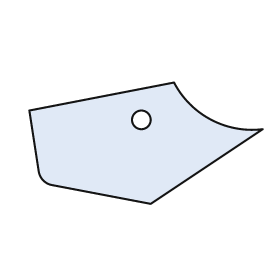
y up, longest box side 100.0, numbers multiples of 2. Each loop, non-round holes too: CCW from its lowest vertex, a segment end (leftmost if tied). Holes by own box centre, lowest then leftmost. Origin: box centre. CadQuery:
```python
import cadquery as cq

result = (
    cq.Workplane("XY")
    .moveTo(2.0, -26.0)
    .lineTo(50.0, 6.0)
    .threePointArc((28.0, 10.0), (12.0, 26.0))
    .lineTo(-50.0, 14.0)
    .lineTo(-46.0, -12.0)
    .threePointArc((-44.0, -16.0), (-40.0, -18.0))
    .close()
    .moveTo(-2.0, 10.0)
    .circle(4.0)
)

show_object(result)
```